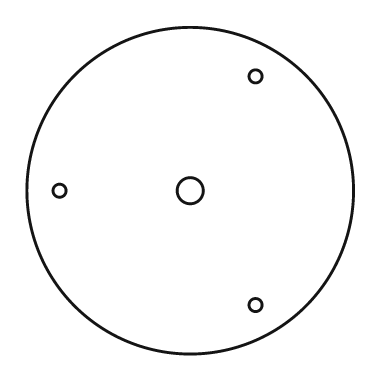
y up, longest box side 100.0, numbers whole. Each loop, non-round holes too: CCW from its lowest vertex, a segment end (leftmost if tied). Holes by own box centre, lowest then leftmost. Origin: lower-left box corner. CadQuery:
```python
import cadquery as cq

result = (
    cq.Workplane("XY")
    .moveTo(50.0, 50.0)
    .circle(50.0)
    .moveTo(70.0, 15.0)
    .circle(2.0)
    .moveTo(10.0, 50.0)
    .circle(2.0)
    .moveTo(50.0, 50.0)
    .circle(4.0)
    .moveTo(70.0, 85.0)
    .circle(2.0)
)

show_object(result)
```